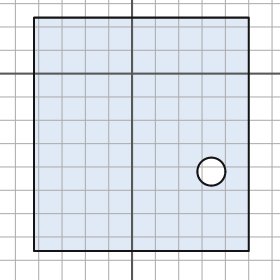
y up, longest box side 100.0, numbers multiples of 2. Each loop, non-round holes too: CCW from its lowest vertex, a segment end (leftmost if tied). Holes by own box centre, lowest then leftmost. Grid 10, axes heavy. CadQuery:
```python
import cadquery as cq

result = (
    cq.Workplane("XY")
    .moveTo(-42.0, -76.0)
    .lineTo(50.0, -76.0)
    .lineTo(50.0, 24.0)
    .lineTo(-42.0, 24.0)
    .close()
    .moveTo(34.0, -42.0)
    .circle(6.0)
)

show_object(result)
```